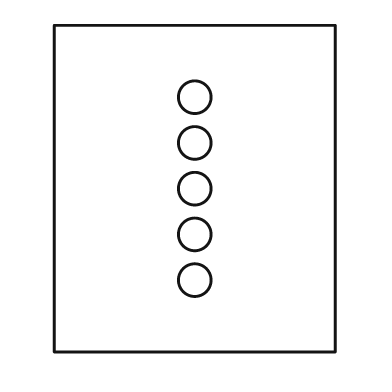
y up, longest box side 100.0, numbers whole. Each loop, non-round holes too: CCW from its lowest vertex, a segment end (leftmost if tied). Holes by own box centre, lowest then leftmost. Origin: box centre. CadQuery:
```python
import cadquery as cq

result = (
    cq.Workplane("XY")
    .moveTo(-43.0, -50.0)
    .lineTo(43.0, -50.0)
    .lineTo(43.0, 50.0)
    .lineTo(-43.0, 50.0)
    .close()
    .moveTo(0.0, -28.0)
    .circle(5.0)
    .moveTo(0.0, -14.0)
    .circle(5.0)
    .moveTo(0.0, 0.0)
    .circle(5.0)
    .moveTo(0.0, 14.0)
    .circle(5.0)
    .moveTo(0.0, 28.0)
    .circle(5.0)
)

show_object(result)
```